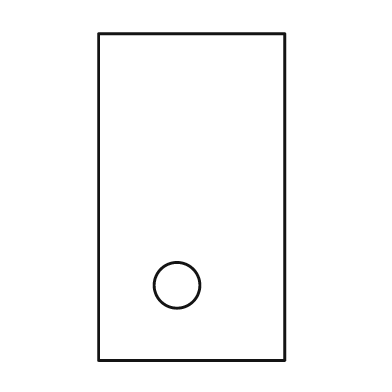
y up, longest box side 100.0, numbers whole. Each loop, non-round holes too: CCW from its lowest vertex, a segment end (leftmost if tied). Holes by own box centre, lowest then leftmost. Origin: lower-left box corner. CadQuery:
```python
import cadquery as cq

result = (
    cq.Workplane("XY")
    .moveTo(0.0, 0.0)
    .lineTo(57.0, 0.0)
    .lineTo(57.0, 100.0)
    .lineTo(0.0, 100.0)
    .close()
    .moveTo(24.0, 23.0)
    .circle(7.0)
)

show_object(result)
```